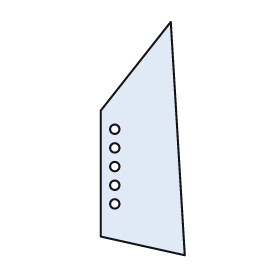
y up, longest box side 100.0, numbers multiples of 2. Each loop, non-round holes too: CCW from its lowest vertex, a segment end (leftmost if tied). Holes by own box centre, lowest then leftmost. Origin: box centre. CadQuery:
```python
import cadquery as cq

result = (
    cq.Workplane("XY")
    .moveTo(18.0, -50.0)
    .lineTo(12.0, 50.0)
    .lineTo(-18.0, 12.0)
    .lineTo(-18.0, -42.0)
    .close()
    .moveTo(-12.0, -28.0)
    .circle(2.0)
    .moveTo(-12.0, -20.0)
    .circle(2.0)
    .moveTo(-12.0, -12.0)
    .circle(2.0)
    .moveTo(-12.0, -4.0)
    .circle(2.0)
    .moveTo(-12.0, 4.0)
    .circle(2.0)
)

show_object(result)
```